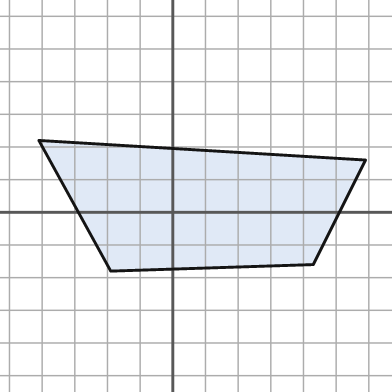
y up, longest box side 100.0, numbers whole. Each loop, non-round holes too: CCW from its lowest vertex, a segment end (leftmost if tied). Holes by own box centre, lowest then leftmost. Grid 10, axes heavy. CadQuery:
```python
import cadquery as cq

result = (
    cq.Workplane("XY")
    .moveTo(-19.0, -18.0)
    .lineTo(43.0, -16.0)
    .lineTo(59.0, 16.0)
    .lineTo(-41.0, 22.0)
    .close()
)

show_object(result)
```